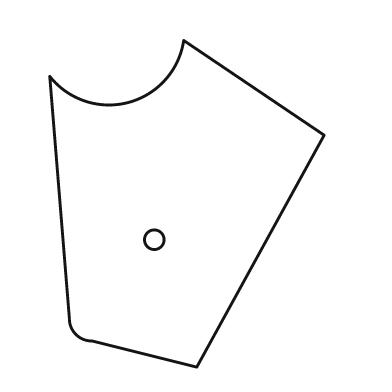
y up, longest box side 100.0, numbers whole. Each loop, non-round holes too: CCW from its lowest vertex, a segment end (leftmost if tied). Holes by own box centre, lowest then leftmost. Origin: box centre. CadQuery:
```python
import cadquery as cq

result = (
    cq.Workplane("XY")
    .moveTo(3.0, -50.0)
    .lineTo(42.0, 21.0)
    .lineTo(-1.0, 50.0)
    .threePointArc((-18.0, 31.0), (-42.0, 39.0))
    .lineTo(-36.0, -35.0)
    .threePointArc((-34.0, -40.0), (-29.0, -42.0))
    .close()
    .moveTo(-10.0, -11.0)
    .circle(3.0)
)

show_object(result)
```